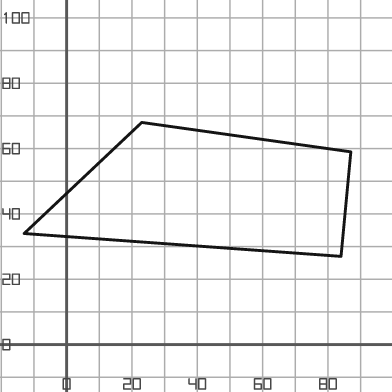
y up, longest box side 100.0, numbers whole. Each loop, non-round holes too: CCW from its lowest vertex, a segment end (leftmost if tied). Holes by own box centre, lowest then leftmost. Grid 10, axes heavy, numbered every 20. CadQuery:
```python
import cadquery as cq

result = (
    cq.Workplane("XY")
    .moveTo(84.0, 27.0)
    .lineTo(87.0, 59.0)
    .lineTo(23.0, 68.0)
    .lineTo(-13.0, 34.0)
    .close()
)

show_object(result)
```